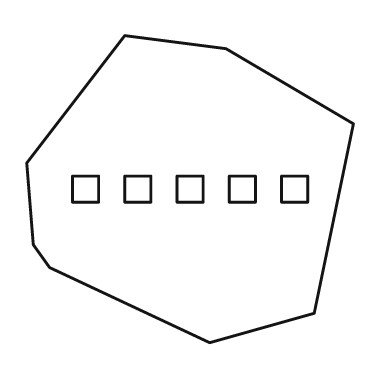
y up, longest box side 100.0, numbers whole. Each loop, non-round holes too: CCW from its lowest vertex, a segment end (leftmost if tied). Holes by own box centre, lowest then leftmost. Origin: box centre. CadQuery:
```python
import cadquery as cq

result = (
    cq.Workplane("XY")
    .moveTo(6.0, -47.0)
    .lineTo(38.0, -38.0)
    .lineTo(50.0, 20.0)
    .lineTo(11.0, 43.0)
    .lineTo(-20.0, 47.0)
    .lineTo(-50.0, 8.0)
    .lineTo(-48.0, -17.0)
    .lineTo(-43.0, -24.0)
    .close()
    .moveTo(-36.0, -4.0)
    .lineTo(-28.0, -4.0)
    .lineTo(-28.0, 4.0)
    .lineTo(-36.0, 4.0)
    .close()
    .moveTo(-20.0, -4.0)
    .lineTo(-12.0, -4.0)
    .lineTo(-12.0, 4.0)
    .lineTo(-20.0, 4.0)
    .close()
    .moveTo(-4.0, -4.0)
    .lineTo(4.0, -4.0)
    .lineTo(4.0, 4.0)
    .lineTo(-4.0, 4.0)
    .close()
    .moveTo(12.0, -4.0)
    .lineTo(20.0, -4.0)
    .lineTo(20.0, 4.0)
    .lineTo(12.0, 4.0)
    .close()
    .moveTo(28.0, -4.0)
    .lineTo(36.0, -4.0)
    .lineTo(36.0, 4.0)
    .lineTo(28.0, 4.0)
    .close()
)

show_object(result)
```